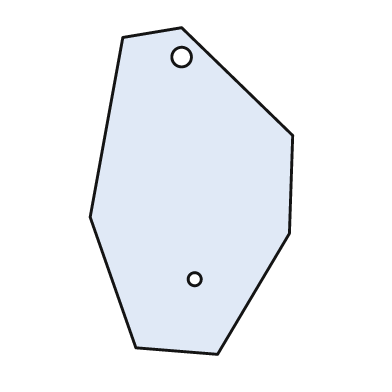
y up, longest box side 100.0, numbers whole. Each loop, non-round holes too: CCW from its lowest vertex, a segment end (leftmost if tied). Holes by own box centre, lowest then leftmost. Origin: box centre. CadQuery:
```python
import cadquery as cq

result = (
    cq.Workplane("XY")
    .moveTo(8.0, -50.0)
    .lineTo(30.0, -13.0)
    .lineTo(31.0, 17.0)
    .lineTo(-3.0, 50.0)
    .lineTo(-21.0, 47.0)
    .lineTo(-31.0, -8.0)
    .lineTo(-17.0, -48.0)
    .close()
    .moveTo(1.0, -27.0)
    .circle(2.0)
    .moveTo(-3.0, 41.0)
    .circle(3.0)
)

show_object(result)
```